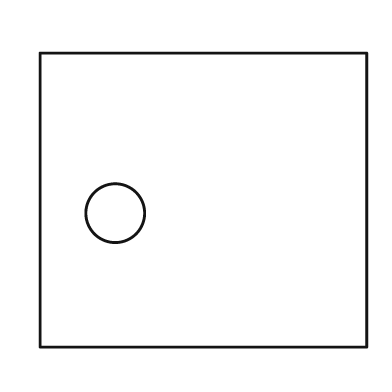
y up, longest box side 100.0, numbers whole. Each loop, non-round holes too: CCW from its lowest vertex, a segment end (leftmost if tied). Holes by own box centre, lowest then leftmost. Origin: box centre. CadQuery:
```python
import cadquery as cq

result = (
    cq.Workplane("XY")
    .moveTo(-50.0, -45.0)
    .lineTo(50.0, -45.0)
    .lineTo(50.0, 45.0)
    .lineTo(-50.0, 45.0)
    .close()
    .moveTo(-27.0, -4.0)
    .circle(9.0)
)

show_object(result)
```